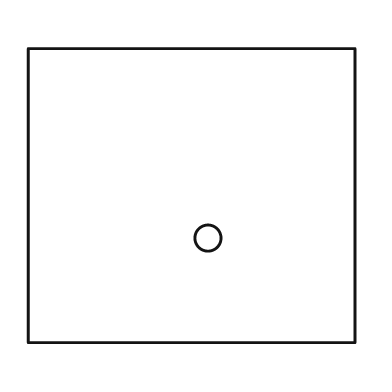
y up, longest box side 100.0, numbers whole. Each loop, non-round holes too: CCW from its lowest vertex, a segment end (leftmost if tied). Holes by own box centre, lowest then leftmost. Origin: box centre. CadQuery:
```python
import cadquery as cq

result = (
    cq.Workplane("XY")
    .moveTo(-50.0, -45.0)
    .lineTo(50.0, -45.0)
    .lineTo(50.0, 45.0)
    .lineTo(-50.0, 45.0)
    .close()
    .moveTo(5.0, -13.0)
    .circle(4.0)
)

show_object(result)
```